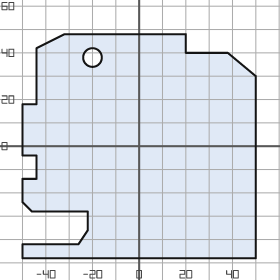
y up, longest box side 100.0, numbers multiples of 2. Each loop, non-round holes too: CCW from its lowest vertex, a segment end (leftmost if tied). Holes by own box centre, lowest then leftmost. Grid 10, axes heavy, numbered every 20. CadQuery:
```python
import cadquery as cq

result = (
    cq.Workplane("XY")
    .moveTo(-50.0, -48.0)
    .lineTo(50.0, -48.0)
    .lineTo(50.0, 30.0)
    .lineTo(38.0, 40.0)
    .lineTo(20.0, 40.0)
    .lineTo(20.0, 48.0)
    .lineTo(-32.0, 48.0)
    .lineTo(-44.0, 42.0)
    .lineTo(-44.0, 18.0)
    .lineTo(-50.0, 18.0)
    .lineTo(-50.0, -4.0)
    .lineTo(-44.0, -4.0)
    .lineTo(-44.0, -14.0)
    .lineTo(-50.0, -14.0)
    .lineTo(-50.0, -24.0)
    .lineTo(-46.0, -28.0)
    .lineTo(-22.0, -28.0)
    .lineTo(-22.0, -36.0)
    .lineTo(-26.0, -42.0)
    .lineTo(-50.0, -42.0)
    .close()
    .moveTo(-20.0, 38.0)
    .circle(4.0)
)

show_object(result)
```